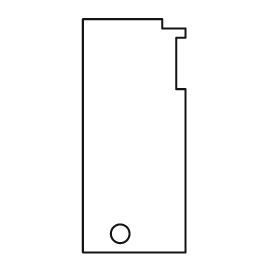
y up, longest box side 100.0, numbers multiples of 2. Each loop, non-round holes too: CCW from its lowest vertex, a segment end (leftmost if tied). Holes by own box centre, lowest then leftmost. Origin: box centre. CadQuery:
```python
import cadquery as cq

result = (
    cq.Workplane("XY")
    .moveTo(-22.0, -50.0)
    .lineTo(22.0, -50.0)
    .lineTo(22.0, 20.0)
    .lineTo(18.0, 20.0)
    .lineTo(18.0, 42.0)
    .lineTo(22.0, 42.0)
    .lineTo(22.0, 46.0)
    .lineTo(12.0, 46.0)
    .lineTo(12.0, 50.0)
    .lineTo(-22.0, 50.0)
    .close()
    .moveTo(-6.0, -42.0)
    .circle(4.0)
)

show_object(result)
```